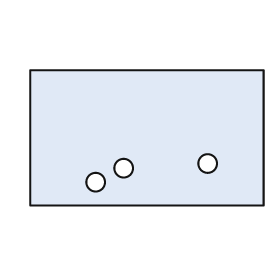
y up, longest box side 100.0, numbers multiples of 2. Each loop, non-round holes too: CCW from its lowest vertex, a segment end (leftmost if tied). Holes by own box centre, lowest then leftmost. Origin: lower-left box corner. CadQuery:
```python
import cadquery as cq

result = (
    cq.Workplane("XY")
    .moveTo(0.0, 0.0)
    .lineTo(100.0, 0.0)
    .lineTo(100.0, 58.0)
    .lineTo(0.0, 58.0)
    .close()
    .moveTo(28.0, 10.0)
    .circle(4.0)
    .moveTo(40.0, 16.0)
    .circle(4.0)
    .moveTo(76.0, 18.0)
    .circle(4.0)
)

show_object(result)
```